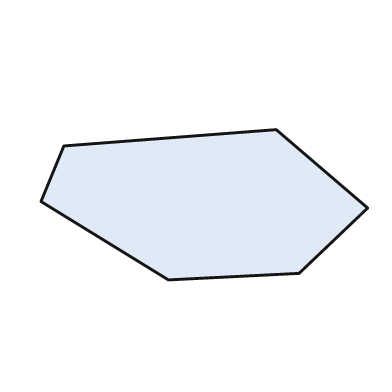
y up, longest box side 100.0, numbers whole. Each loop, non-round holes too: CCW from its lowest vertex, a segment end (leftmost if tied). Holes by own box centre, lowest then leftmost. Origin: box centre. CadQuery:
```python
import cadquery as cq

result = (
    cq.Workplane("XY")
    .moveTo(-11.0, -23.0)
    .lineTo(29.0, -21.0)
    .lineTo(50.0, -1.0)
    .lineTo(22.0, 23.0)
    .lineTo(-43.0, 18.0)
    .lineTo(-50.0, 1.0)
    .close()
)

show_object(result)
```